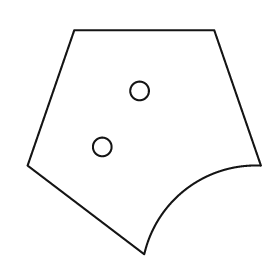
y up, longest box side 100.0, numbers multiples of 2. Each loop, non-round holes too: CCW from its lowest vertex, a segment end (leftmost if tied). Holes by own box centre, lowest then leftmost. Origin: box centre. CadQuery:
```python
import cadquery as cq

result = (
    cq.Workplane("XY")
    .moveTo(0.0, -48.0)
    .threePointArc((18.0, -20.0), (50.0, -10.0))
    .lineTo(30.0, 48.0)
    .lineTo(-30.0, 48.0)
    .lineTo(-50.0, -10.0)
    .close()
    .moveTo(-18.0, -2.0)
    .circle(4.0)
    .moveTo(-2.0, 22.0)
    .circle(4.0)
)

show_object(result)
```